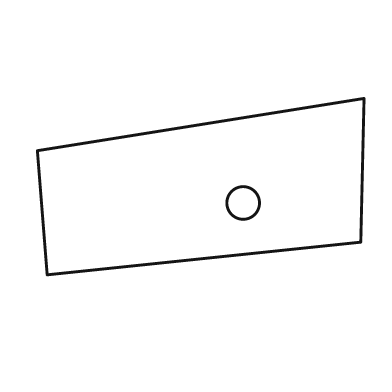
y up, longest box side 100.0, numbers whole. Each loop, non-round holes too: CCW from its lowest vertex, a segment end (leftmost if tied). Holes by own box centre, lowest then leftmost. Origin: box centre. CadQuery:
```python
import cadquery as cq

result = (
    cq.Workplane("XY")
    .moveTo(-47.0, -27.0)
    .lineTo(49.0, -17.0)
    .lineTo(50.0, 27.0)
    .lineTo(-50.0, 11.0)
    .close()
    .moveTo(13.0, -5.0)
    .circle(5.0)
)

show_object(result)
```